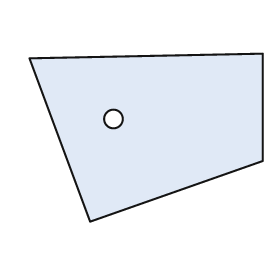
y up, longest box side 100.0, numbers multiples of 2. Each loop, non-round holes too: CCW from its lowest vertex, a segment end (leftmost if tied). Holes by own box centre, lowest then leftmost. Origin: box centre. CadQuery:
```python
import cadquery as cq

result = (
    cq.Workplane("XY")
    .moveTo(-24.0, -36.0)
    .lineTo(50.0, -10.0)
    .lineTo(50.0, 36.0)
    .lineTo(-50.0, 34.0)
    .close()
    .moveTo(-14.0, 8.0)
    .circle(4.0)
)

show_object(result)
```